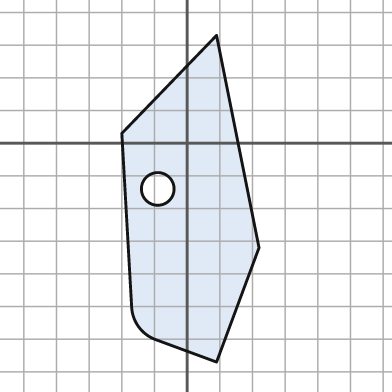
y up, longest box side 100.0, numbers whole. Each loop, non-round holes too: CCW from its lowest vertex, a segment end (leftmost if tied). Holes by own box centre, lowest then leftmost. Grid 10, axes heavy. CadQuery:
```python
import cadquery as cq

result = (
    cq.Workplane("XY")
    .moveTo(9.0, -67.0)
    .lineTo(22.0, -32.0)
    .lineTo(9.0, 33.0)
    .lineTo(-20.0, 3.0)
    .lineTo(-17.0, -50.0)
    .threePointArc((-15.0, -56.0), (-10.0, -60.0))
    .close()
    .moveTo(-9.0, -14.0)
    .circle(5.0)
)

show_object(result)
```